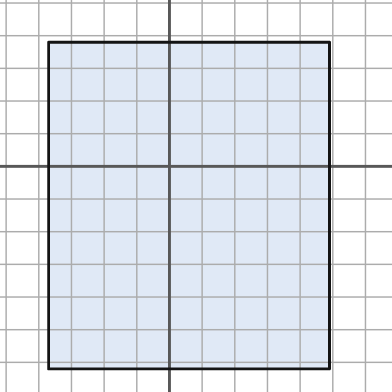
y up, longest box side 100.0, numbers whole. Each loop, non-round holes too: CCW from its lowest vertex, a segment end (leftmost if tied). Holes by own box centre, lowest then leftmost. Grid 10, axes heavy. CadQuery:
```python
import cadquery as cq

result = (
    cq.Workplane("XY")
    .moveTo(-37.0, -62.0)
    .lineTo(49.0, -62.0)
    .lineTo(49.0, 38.0)
    .lineTo(-37.0, 38.0)
    .close()
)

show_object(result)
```